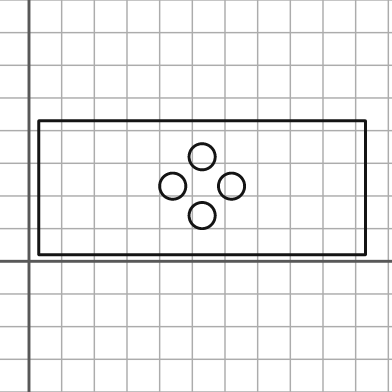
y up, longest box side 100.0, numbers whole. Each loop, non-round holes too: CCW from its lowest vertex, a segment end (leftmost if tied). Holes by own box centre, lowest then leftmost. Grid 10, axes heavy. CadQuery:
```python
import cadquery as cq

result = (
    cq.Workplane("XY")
    .moveTo(3.0, 2.0)
    .lineTo(103.0, 2.0)
    .lineTo(103.0, 43.0)
    .lineTo(3.0, 43.0)
    .close()
    .moveTo(53.0, 14.0)
    .circle(4.0)
    .moveTo(44.0, 23.0)
    .circle(4.0)
    .moveTo(62.0, 23.0)
    .circle(4.0)
    .moveTo(53.0, 32.0)
    .circle(4.0)
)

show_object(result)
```